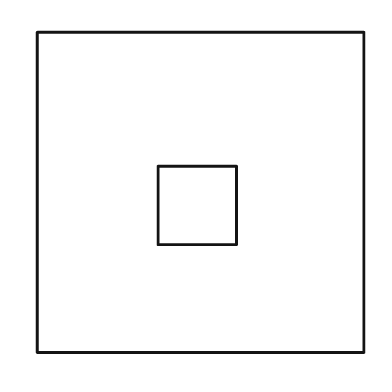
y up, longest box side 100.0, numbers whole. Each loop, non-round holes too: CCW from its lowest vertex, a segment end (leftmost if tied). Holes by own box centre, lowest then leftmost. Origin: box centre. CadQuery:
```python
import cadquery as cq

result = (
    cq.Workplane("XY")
    .moveTo(-50.0, -49.0)
    .lineTo(50.0, -49.0)
    .lineTo(50.0, 49.0)
    .lineTo(-50.0, 49.0)
    .close()
    .moveTo(-13.0, -16.0)
    .lineTo(11.0, -16.0)
    .lineTo(11.0, 8.0)
    .lineTo(-13.0, 8.0)
    .close()
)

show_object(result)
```